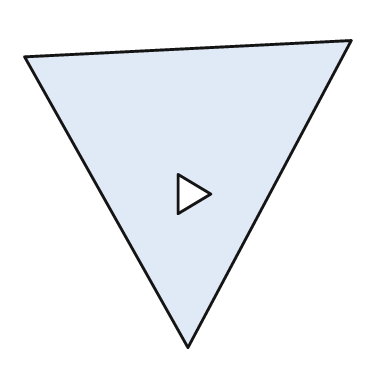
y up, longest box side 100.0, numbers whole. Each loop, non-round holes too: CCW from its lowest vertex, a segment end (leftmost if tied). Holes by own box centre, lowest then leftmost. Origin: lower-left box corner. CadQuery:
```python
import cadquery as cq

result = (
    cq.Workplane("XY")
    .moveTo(50.0, 0.0)
    .lineTo(100.0, 94.0)
    .lineTo(0.0, 89.0)
    .close()
    .moveTo(47.0, 41.0)
    .lineTo(57.0, 47.0)
    .lineTo(47.0, 53.0)
    .close()
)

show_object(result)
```